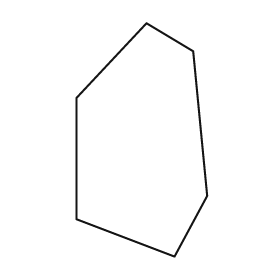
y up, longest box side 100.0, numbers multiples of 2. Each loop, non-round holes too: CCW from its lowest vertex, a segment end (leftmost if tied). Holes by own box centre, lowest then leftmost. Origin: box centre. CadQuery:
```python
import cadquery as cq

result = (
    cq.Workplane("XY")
    .moveTo(14.0, -50.0)
    .lineTo(28.0, -24.0)
    .lineTo(22.0, 38.0)
    .lineTo(2.0, 50.0)
    .lineTo(-28.0, 18.0)
    .lineTo(-28.0, -34.0)
    .close()
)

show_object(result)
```